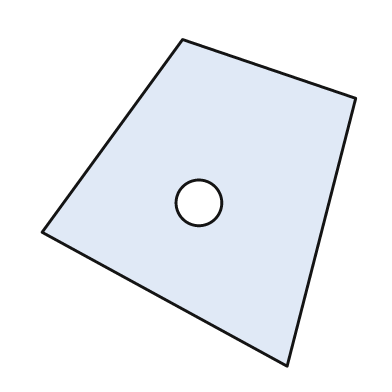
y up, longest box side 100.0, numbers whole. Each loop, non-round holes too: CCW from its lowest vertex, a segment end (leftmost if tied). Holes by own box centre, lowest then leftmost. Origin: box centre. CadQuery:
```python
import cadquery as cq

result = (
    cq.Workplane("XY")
    .moveTo(27.0, -50.0)
    .lineTo(48.0, 32.0)
    .lineTo(-5.0, 50.0)
    .lineTo(-48.0, -9.0)
    .close()
    .moveTo(0.0, 0.0)
    .circle(7.0)
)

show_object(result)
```